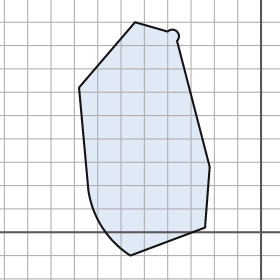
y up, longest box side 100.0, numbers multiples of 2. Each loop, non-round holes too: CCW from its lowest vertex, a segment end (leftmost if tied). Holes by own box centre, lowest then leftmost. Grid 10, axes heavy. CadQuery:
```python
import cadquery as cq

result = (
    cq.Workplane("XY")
    .moveTo(-56.0, -10.0)
    .lineTo(-24.0, 2.0)
    .lineTo(-22.0, 28.0)
    .lineTo(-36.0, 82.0)
    .threePointArc((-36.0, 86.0), (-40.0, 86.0))
    .lineTo(-54.0, 90.0)
    .lineTo(-78.0, 62.0)
    .lineTo(-74.0, 18.0)
    .threePointArc((-68.0, 2.0), (-56.0, -10.0))
    .close()
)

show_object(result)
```